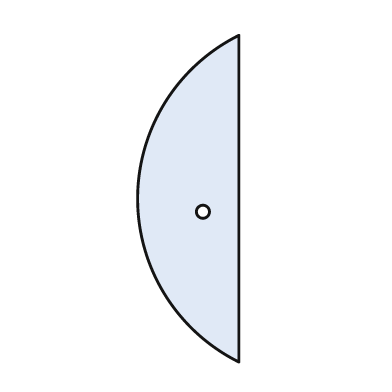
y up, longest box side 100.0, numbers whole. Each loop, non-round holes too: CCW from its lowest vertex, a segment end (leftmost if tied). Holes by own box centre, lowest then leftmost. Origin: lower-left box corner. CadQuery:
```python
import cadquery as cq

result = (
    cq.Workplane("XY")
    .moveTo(31.0, 0.0)
    .lineTo(31.0, 100.0)
    .threePointArc((0.0, 50.0), (31.0, 0.0))
    .close()
    .moveTo(20.0, 46.0)
    .circle(2.0)
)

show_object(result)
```